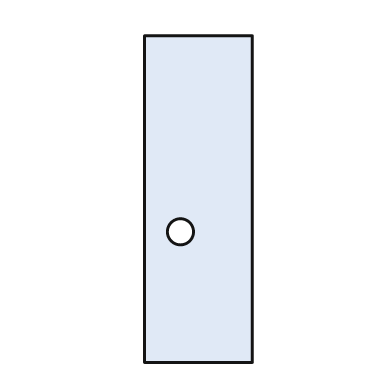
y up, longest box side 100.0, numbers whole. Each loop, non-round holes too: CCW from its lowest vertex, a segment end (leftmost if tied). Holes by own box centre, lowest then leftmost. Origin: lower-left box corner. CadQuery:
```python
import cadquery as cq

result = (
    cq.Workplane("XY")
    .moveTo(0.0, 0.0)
    .lineTo(33.0, 0.0)
    .lineTo(33.0, 100.0)
    .lineTo(0.0, 100.0)
    .close()
    .moveTo(11.0, 40.0)
    .circle(4.0)
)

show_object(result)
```